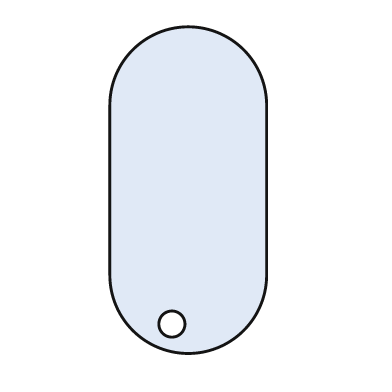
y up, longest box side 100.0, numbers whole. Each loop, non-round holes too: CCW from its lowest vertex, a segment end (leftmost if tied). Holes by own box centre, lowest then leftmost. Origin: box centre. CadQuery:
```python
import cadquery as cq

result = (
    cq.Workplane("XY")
    .moveTo(-24.0, -26.0)
    .threePointArc((0.0, -50.0), (24.0, -26.0))
    .lineTo(24.0, 26.0)
    .threePointArc((0.0, 50.0), (-24.0, 26.0))
    .close()
    .moveTo(-5.0, -41.0)
    .circle(4.0)
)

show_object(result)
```